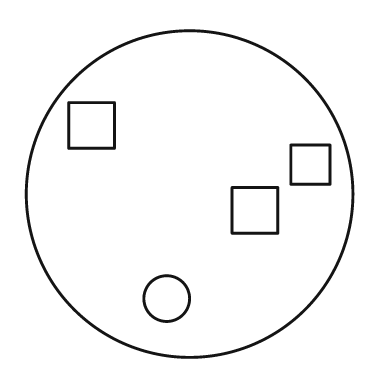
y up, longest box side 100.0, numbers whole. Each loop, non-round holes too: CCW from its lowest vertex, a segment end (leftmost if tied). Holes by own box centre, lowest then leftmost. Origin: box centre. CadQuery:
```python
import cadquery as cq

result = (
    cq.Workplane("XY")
    .moveTo(0.0, 0.0)
    .circle(50.0)
    .moveTo(-7.0, -32.0)
    .circle(7.0)
    .moveTo(13.0, -12.0)
    .lineTo(27.0, -12.0)
    .lineTo(27.0, 2.0)
    .lineTo(13.0, 2.0)
    .close()
    .moveTo(31.0, 3.0)
    .lineTo(43.0, 3.0)
    .lineTo(43.0, 15.0)
    .lineTo(31.0, 15.0)
    .close()
    .moveTo(-37.0, 14.0)
    .lineTo(-23.0, 14.0)
    .lineTo(-23.0, 28.0)
    .lineTo(-37.0, 28.0)
    .close()
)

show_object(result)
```